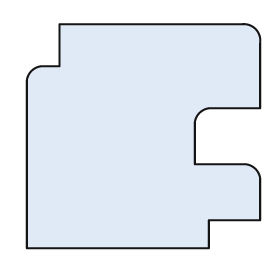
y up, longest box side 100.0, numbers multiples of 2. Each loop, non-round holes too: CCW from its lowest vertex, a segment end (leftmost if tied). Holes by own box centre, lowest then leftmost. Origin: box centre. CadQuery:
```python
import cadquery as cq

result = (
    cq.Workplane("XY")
    .moveTo(-50.0, -48.0)
    .lineTo(28.0, -48.0)
    .lineTo(28.0, -36.0)
    .lineTo(50.0, -36.0)
    .lineTo(50.0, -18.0)
    .threePointArc((48.0, -14.0), (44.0, -12.0))
    .lineTo(22.0, -12.0)
    .lineTo(22.0, 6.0)
    .threePointArc((24.0, 10.0), (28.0, 12.0))
    .lineTo(50.0, 12.0)
    .lineTo(50.0, 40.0)
    .threePointArc((48.0, 46.0), (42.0, 48.0))
    .lineTo(-36.0, 48.0)
    .lineTo(-36.0, 30.0)
    .lineTo(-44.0, 30.0)
    .threePointArc((-48.0, 28.0), (-50.0, 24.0))
    .close()
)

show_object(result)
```